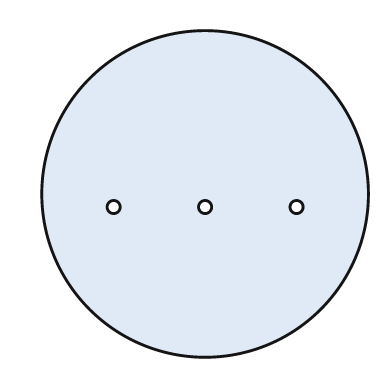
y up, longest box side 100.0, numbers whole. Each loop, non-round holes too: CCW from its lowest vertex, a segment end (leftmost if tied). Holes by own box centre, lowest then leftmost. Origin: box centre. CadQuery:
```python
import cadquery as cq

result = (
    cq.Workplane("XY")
    .moveTo(0.0, 0.0)
    .circle(50.0)
    .moveTo(-28.0, -4.0)
    .circle(2.0)
    .moveTo(0.0, -4.0)
    .circle(2.0)
    .moveTo(28.0, -4.0)
    .circle(2.0)
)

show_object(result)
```